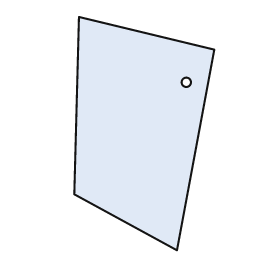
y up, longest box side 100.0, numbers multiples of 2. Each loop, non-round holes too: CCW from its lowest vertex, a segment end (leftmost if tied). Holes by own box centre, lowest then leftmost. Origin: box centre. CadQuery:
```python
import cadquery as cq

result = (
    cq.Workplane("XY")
    .moveTo(14.0, -50.0)
    .lineTo(30.0, 36.0)
    .lineTo(-28.0, 50.0)
    .lineTo(-30.0, -26.0)
    .close()
    .moveTo(18.0, 22.0)
    .circle(2.0)
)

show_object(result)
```